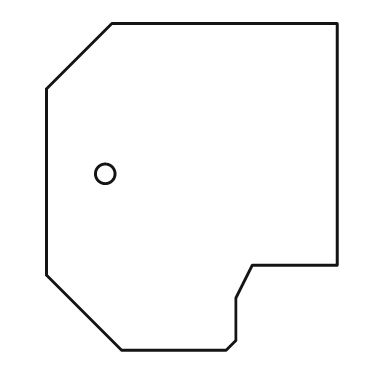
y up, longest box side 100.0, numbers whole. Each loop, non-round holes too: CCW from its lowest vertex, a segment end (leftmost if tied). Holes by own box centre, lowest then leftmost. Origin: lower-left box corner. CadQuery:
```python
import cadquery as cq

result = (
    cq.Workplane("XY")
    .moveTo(23.0, 0.0)
    .lineTo(55.0, 0.0)
    .lineTo(58.0, 3.0)
    .lineTo(58.0, 16.0)
    .lineTo(63.0, 26.0)
    .lineTo(89.0, 26.0)
    .lineTo(89.0, 100.0)
    .lineTo(20.0, 100.0)
    .lineTo(0.0, 80.0)
    .lineTo(0.0, 23.0)
    .close()
    .moveTo(18.0, 54.0)
    .circle(3.0)
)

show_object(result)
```